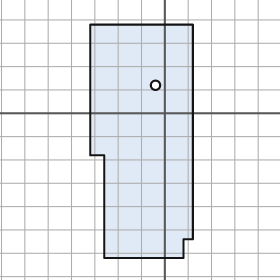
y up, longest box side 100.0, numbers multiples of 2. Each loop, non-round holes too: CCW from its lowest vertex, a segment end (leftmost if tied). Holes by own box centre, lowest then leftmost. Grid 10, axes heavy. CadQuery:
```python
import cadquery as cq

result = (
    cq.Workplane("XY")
    .moveTo(-26.0, -62.0)
    .lineTo(8.0, -62.0)
    .lineTo(8.0, -54.0)
    .lineTo(12.0, -54.0)
    .lineTo(12.0, 38.0)
    .lineTo(-32.0, 38.0)
    .lineTo(-32.0, -18.0)
    .lineTo(-26.0, -18.0)
    .close()
    .moveTo(-4.0, 12.0)
    .circle(2.0)
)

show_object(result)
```